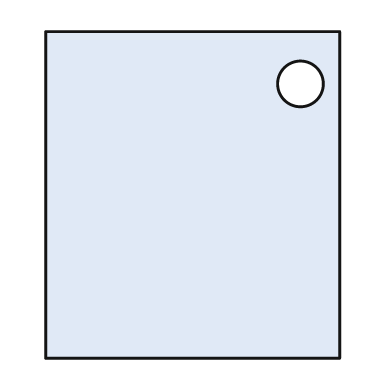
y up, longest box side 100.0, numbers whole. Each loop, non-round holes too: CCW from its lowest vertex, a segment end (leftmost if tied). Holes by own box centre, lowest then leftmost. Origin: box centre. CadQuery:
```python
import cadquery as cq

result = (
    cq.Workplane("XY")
    .moveTo(-45.0, -50.0)
    .lineTo(45.0, -50.0)
    .lineTo(45.0, 50.0)
    .lineTo(-45.0, 50.0)
    .close()
    .moveTo(33.0, 34.0)
    .circle(7.0)
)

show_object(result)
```